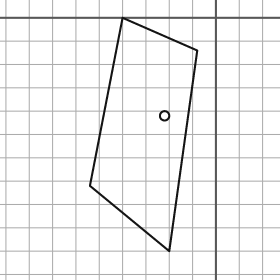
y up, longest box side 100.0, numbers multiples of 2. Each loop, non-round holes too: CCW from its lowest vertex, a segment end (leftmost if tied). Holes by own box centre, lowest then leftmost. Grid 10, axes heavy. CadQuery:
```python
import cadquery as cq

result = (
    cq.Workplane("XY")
    .moveTo(-20.0, -100.0)
    .lineTo(-8.0, -14.0)
    .lineTo(-40.0, 0.0)
    .lineTo(-54.0, -72.0)
    .close()
    .moveTo(-22.0, -42.0)
    .circle(2.0)
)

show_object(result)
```